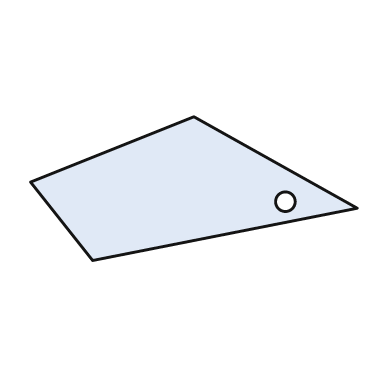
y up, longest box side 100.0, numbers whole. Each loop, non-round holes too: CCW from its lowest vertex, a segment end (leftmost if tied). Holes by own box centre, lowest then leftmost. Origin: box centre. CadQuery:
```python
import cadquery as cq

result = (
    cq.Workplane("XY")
    .moveTo(-31.0, -22.0)
    .lineTo(50.0, -6.0)
    .lineTo(0.0, 22.0)
    .lineTo(-50.0, 2.0)
    .close()
    .moveTo(28.0, -4.0)
    .circle(3.0)
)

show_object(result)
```